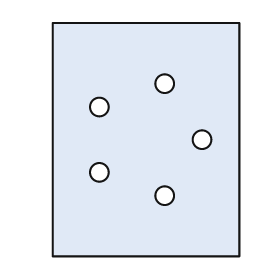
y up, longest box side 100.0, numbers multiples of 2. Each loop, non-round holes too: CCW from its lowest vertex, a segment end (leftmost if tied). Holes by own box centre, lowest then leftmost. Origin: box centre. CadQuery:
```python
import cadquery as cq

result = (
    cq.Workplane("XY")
    .moveTo(-40.0, -50.0)
    .lineTo(40.0, -50.0)
    .lineTo(40.0, 50.0)
    .lineTo(-40.0, 50.0)
    .close()
    .moveTo(8.0, -24.0)
    .circle(4.0)
    .moveTo(-20.0, -14.0)
    .circle(4.0)
    .moveTo(24.0, 0.0)
    .circle(4.0)
    .moveTo(-20.0, 14.0)
    .circle(4.0)
    .moveTo(8.0, 24.0)
    .circle(4.0)
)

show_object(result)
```